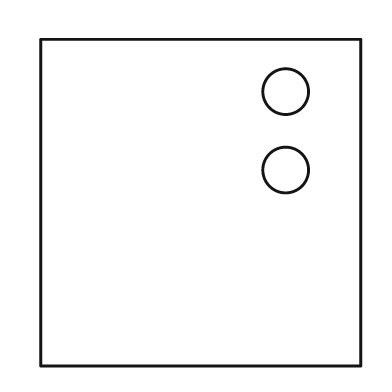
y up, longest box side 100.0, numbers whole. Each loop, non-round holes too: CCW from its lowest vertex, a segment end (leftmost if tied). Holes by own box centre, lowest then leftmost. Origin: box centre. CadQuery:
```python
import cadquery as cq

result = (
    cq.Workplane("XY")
    .moveTo(-49.0, -50.0)
    .lineTo(49.0, -50.0)
    .lineTo(49.0, 50.0)
    .lineTo(-49.0, 50.0)
    .close()
    .moveTo(26.0, 10.0)
    .circle(7.0)
    .moveTo(26.0, 34.0)
    .circle(7.0)
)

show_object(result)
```